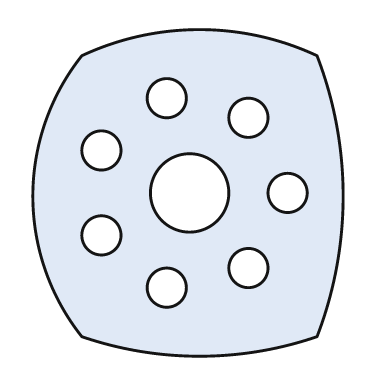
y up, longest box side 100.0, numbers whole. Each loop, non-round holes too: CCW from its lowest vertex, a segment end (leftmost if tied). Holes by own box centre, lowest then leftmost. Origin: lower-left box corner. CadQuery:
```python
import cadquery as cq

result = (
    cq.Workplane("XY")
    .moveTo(15.0, 6.0)
    .threePointArc((51.0, 0.0), (87.0, 6.0))
    .threePointArc((95.0, 49.0), (87.0, 92.0))
    .threePointArc((51.0, 100.0), (15.0, 92.0))
    .threePointArc((0.0, 49.0), (15.0, 6.0))
    .close()
    .moveTo(41.0, 21.0)
    .circle(6.0)
    .moveTo(66.0, 27.0)
    .circle(6.0)
    .moveTo(21.0, 37.0)
    .circle(6.0)
    .moveTo(48.0, 50.0)
    .circle(12.0)
    .moveTo(78.0, 50.0)
    .circle(6.0)
    .moveTo(21.0, 63.0)
    .circle(6.0)
    .moveTo(66.0, 73.0)
    .circle(6.0)
    .moveTo(41.0, 79.0)
    .circle(6.0)
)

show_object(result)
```